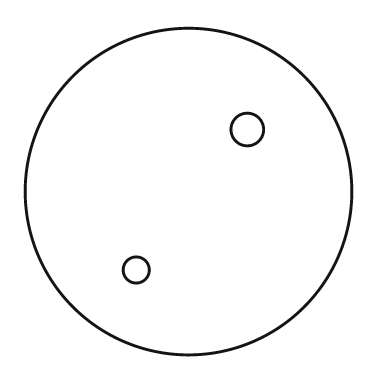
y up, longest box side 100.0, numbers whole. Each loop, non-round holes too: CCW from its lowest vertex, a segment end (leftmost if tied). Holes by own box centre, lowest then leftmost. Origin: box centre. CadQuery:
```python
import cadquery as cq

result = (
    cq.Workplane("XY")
    .moveTo(0.0, 0.0)
    .circle(50.0)
    .moveTo(-16.0, -24.0)
    .circle(4.0)
    .moveTo(18.0, 19.0)
    .circle(5.0)
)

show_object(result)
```